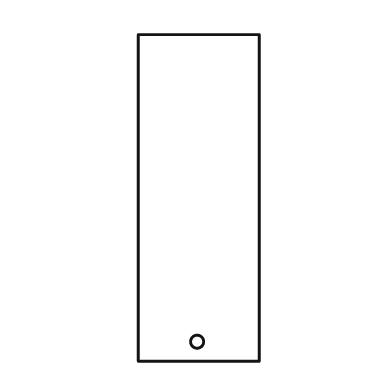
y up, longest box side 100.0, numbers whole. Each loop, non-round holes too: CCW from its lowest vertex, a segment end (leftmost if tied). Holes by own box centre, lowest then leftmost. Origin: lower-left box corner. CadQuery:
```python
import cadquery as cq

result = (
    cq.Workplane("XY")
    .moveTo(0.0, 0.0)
    .lineTo(37.0, 0.0)
    .lineTo(37.0, 100.0)
    .lineTo(0.0, 100.0)
    .close()
    .moveTo(18.0, 6.0)
    .circle(2.0)
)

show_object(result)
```